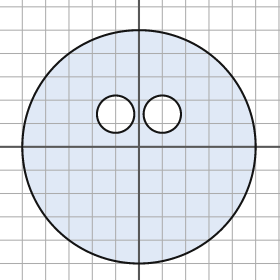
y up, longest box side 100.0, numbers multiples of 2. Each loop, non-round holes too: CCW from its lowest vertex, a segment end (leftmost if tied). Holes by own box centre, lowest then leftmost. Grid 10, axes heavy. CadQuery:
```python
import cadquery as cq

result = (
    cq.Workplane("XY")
    .moveTo(0.0, 0.0)
    .circle(50.0)
    .moveTo(-10.0, 14.0)
    .circle(8.0)
    .moveTo(10.0, 14.0)
    .circle(8.0)
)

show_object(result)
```